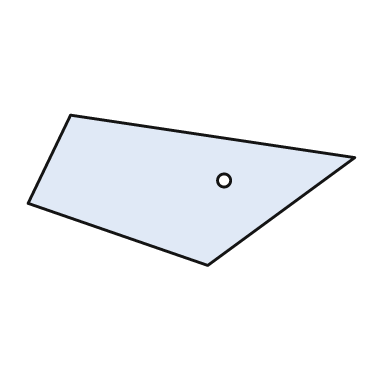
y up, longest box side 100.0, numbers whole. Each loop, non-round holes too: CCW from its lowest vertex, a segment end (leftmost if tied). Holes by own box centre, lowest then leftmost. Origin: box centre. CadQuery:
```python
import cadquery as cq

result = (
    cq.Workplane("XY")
    .moveTo(5.0, -23.0)
    .lineTo(50.0, 10.0)
    .lineTo(-37.0, 23.0)
    .lineTo(-50.0, -4.0)
    .close()
    .moveTo(10.0, 3.0)
    .circle(2.0)
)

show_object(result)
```